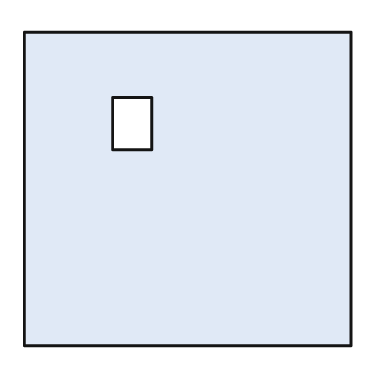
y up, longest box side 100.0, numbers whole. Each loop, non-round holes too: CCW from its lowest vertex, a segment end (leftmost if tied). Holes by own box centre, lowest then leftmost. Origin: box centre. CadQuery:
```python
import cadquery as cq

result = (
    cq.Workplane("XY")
    .moveTo(-50.0, -48.0)
    .lineTo(50.0, -48.0)
    .lineTo(50.0, 48.0)
    .lineTo(-50.0, 48.0)
    .close()
    .moveTo(-23.0, 12.0)
    .lineTo(-11.0, 12.0)
    .lineTo(-11.0, 28.0)
    .lineTo(-23.0, 28.0)
    .close()
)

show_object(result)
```